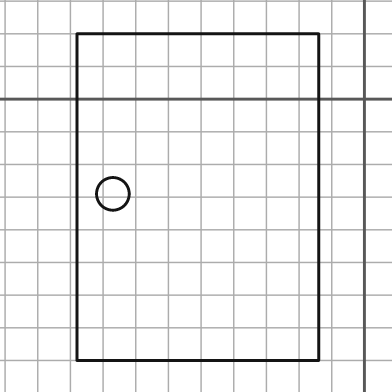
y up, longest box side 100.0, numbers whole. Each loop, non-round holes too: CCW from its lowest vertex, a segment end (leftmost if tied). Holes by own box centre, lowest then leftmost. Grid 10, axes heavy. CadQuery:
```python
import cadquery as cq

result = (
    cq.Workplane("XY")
    .moveTo(-88.0, -80.0)
    .lineTo(-14.0, -80.0)
    .lineTo(-14.0, 20.0)
    .lineTo(-88.0, 20.0)
    .close()
    .moveTo(-77.0, -29.0)
    .circle(5.0)
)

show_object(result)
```